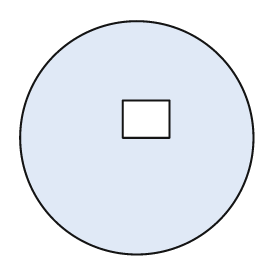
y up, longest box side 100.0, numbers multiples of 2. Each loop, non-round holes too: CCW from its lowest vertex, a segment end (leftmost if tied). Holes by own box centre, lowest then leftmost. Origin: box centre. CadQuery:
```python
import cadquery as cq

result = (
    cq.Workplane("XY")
    .moveTo(0.0, 0.0)
    .circle(50.0)
    .moveTo(-6.0, 0.0)
    .lineTo(14.0, 0.0)
    .lineTo(14.0, 16.0)
    .lineTo(-6.0, 16.0)
    .close()
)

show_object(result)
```